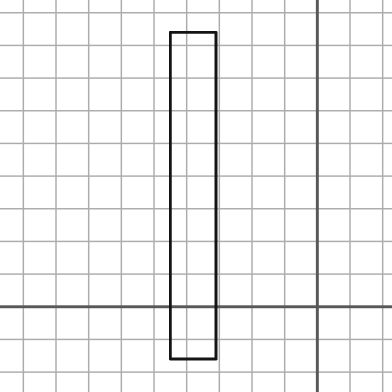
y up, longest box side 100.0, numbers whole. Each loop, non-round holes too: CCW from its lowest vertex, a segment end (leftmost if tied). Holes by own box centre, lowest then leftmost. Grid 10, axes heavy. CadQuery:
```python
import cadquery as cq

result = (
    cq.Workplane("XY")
    .moveTo(-45.0, -16.0)
    .lineTo(-31.0, -16.0)
    .lineTo(-31.0, 84.0)
    .lineTo(-45.0, 84.0)
    .close()
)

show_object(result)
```